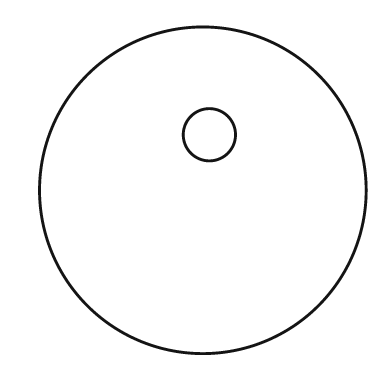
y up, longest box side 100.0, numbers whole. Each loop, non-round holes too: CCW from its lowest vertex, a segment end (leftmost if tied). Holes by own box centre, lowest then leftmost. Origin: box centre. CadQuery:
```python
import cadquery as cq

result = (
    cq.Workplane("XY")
    .moveTo(0.0, 0.0)
    .circle(50.0)
    .moveTo(2.0, 17.0)
    .circle(8.0)
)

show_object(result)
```